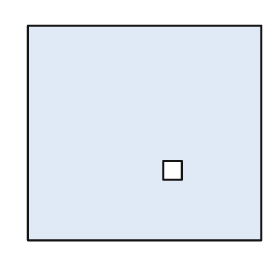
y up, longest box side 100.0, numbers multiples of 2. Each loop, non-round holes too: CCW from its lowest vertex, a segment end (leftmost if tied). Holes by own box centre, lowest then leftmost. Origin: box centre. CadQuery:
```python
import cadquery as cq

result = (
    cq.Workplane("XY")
    .moveTo(-50.0, -46.0)
    .lineTo(50.0, -46.0)
    .lineTo(50.0, 46.0)
    .lineTo(-50.0, 46.0)
    .close()
    .moveTo(8.0, -20.0)
    .lineTo(16.0, -20.0)
    .lineTo(16.0, -12.0)
    .lineTo(8.0, -12.0)
    .close()
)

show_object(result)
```